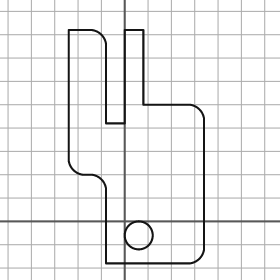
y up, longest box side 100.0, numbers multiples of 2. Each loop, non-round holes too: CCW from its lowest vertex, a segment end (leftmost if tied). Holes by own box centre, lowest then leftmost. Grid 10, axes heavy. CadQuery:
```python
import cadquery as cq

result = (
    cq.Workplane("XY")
    .moveTo(-8.0, -18.0)
    .lineTo(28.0, -18.0)
    .threePointArc((32.0, -16.0), (34.0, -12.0))
    .lineTo(34.0, 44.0)
    .threePointArc((32.0, 48.0), (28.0, 50.0))
    .lineTo(8.0, 50.0)
    .lineTo(8.0, 82.0)
    .lineTo(0.0, 82.0)
    .lineTo(0.0, 42.0)
    .lineTo(-8.0, 42.0)
    .lineTo(-8.0, 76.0)
    .threePointArc((-10.0, 80.0), (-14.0, 82.0))
    .lineTo(-24.0, 82.0)
    .lineTo(-24.0, 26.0)
    .threePointArc((-22.0, 22.0), (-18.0, 20.0))
    .lineTo(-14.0, 20.0)
    .threePointArc((-10.0, 18.0), (-8.0, 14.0))
    .close()
    .moveTo(6.0, -6.0)
    .circle(6.0)
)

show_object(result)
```